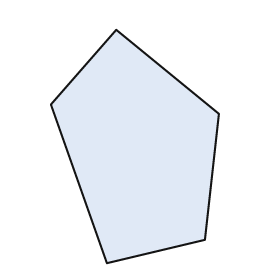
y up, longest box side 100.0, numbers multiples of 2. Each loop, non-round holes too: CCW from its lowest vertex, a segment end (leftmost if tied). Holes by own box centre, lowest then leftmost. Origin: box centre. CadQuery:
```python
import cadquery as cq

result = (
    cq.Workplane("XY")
    .moveTo(-12.0, -50.0)
    .lineTo(30.0, -40.0)
    .lineTo(36.0, 14.0)
    .lineTo(-8.0, 50.0)
    .lineTo(-36.0, 18.0)
    .close()
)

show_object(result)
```